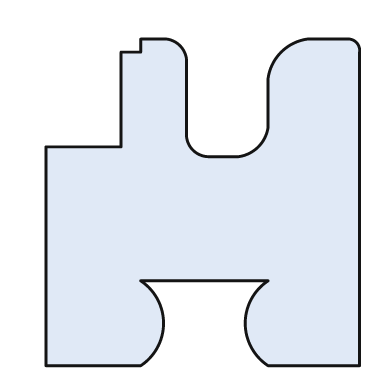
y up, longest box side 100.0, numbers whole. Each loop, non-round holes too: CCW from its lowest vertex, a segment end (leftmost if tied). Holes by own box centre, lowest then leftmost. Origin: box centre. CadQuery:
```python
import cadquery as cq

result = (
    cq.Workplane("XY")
    .moveTo(-48.0, -50.0)
    .lineTo(-19.0, -50.0)
    .threePointArc((-12.0, -37.0), (-19.0, -24.0))
    .lineTo(20.0, -24.0)
    .threePointArc((13.0, -37.0), (20.0, -50.0))
    .lineTo(48.0, -50.0)
    .lineTo(48.0, 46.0)
    .threePointArc((47.0, 49.0), (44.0, 50.0))
    .lineTo(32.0, 50.0)
    .threePointArc((24.0, 46.0), (20.0, 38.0))
    .lineTo(20.0, 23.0)
    .threePointArc((17.0, 17.0), (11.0, 14.0))
    .lineTo(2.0, 14.0)
    .threePointArc((-3.0, 16.0), (-5.0, 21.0))
    .lineTo(-5.0, 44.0)
    .threePointArc((-7.0, 48.0), (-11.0, 50.0))
    .lineTo(-19.0, 50.0)
    .lineTo(-19.0, 46.0)
    .lineTo(-25.0, 46.0)
    .lineTo(-25.0, 17.0)
    .lineTo(-48.0, 17.0)
    .close()
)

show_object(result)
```